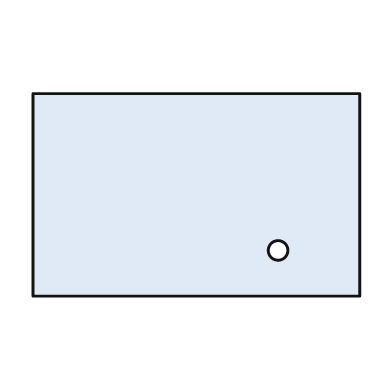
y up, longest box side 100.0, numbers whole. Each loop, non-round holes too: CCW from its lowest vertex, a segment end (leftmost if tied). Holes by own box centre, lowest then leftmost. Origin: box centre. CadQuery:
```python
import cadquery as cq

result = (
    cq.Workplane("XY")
    .moveTo(-50.0, -31.0)
    .lineTo(50.0, -31.0)
    .lineTo(50.0, 31.0)
    .lineTo(-50.0, 31.0)
    .close()
    .moveTo(25.0, -17.0)
    .circle(3.0)
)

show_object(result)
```